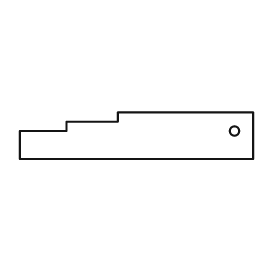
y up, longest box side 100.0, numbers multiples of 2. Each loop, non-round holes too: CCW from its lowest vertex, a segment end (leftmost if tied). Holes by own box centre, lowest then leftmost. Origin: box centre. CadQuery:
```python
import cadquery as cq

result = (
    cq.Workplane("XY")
    .moveTo(-50.0, -10.0)
    .lineTo(50.0, -10.0)
    .lineTo(50.0, 10.0)
    .lineTo(-8.0, 10.0)
    .lineTo(-8.0, 6.0)
    .lineTo(-30.0, 6.0)
    .lineTo(-30.0, 2.0)
    .lineTo(-50.0, 2.0)
    .close()
    .moveTo(42.0, 2.0)
    .circle(2.0)
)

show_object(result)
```